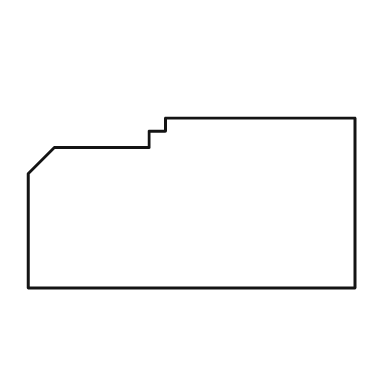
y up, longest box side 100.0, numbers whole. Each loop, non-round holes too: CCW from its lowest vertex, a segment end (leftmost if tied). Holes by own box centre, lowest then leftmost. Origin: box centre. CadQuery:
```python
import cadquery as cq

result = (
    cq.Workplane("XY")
    .moveTo(-50.0, -26.0)
    .lineTo(50.0, -26.0)
    .lineTo(50.0, 26.0)
    .lineTo(-8.0, 26.0)
    .lineTo(-8.0, 22.0)
    .lineTo(-13.0, 22.0)
    .lineTo(-13.0, 17.0)
    .lineTo(-42.0, 17.0)
    .lineTo(-50.0, 9.0)
    .close()
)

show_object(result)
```